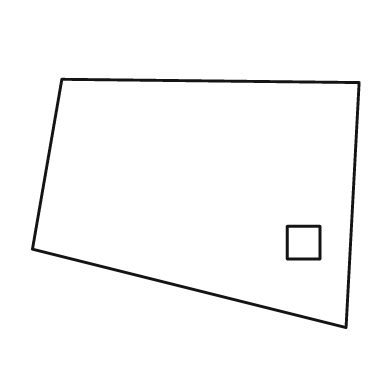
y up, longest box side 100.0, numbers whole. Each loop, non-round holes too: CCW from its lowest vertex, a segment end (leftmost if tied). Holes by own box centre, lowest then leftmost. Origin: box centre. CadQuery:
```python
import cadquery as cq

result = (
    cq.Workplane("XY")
    .moveTo(46.0, -38.0)
    .lineTo(50.0, 37.0)
    .lineTo(-41.0, 38.0)
    .lineTo(-50.0, -14.0)
    .close()
    .moveTo(28.0, -17.0)
    .lineTo(38.0, -17.0)
    .lineTo(38.0, -7.0)
    .lineTo(28.0, -7.0)
    .close()
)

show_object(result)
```